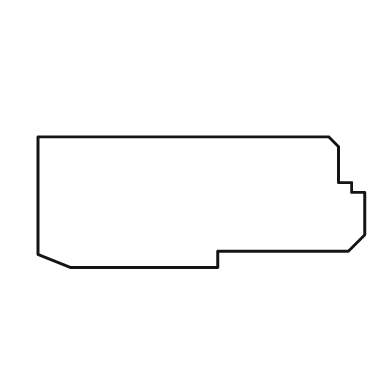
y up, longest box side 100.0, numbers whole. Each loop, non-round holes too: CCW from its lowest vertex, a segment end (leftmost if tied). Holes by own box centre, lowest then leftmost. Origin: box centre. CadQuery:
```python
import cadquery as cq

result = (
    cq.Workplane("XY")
    .moveTo(-40.0, -20.0)
    .lineTo(5.0, -20.0)
    .lineTo(5.0, -15.0)
    .lineTo(45.0, -15.0)
    .lineTo(50.0, -10.0)
    .lineTo(50.0, 3.0)
    .lineTo(46.0, 3.0)
    .lineTo(46.0, 6.0)
    .lineTo(42.0, 6.0)
    .lineTo(42.0, 17.0)
    .lineTo(39.0, 20.0)
    .lineTo(-50.0, 20.0)
    .lineTo(-50.0, -16.0)
    .close()
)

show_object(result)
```